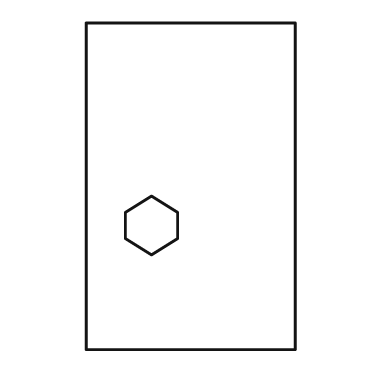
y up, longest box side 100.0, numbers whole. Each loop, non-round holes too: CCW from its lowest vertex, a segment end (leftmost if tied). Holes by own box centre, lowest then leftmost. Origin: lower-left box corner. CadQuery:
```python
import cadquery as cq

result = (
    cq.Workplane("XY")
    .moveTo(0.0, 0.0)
    .lineTo(64.0, 0.0)
    .lineTo(64.0, 100.0)
    .lineTo(0.0, 100.0)
    .close()
    .moveTo(20.0, 29.0)
    .lineTo(28.0, 34.0)
    .lineTo(28.0, 42.0)
    .lineTo(20.0, 47.0)
    .lineTo(12.0, 42.0)
    .lineTo(12.0, 34.0)
    .close()
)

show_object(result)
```